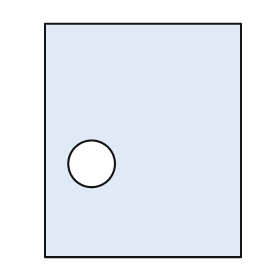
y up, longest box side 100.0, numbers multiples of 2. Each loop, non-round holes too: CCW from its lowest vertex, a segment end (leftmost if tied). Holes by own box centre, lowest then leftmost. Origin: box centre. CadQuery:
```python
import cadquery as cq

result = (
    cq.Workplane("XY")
    .moveTo(-42.0, -50.0)
    .lineTo(42.0, -50.0)
    .lineTo(42.0, 50.0)
    .lineTo(-42.0, 50.0)
    .close()
    .moveTo(-22.0, -10.0)
    .circle(10.0)
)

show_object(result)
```